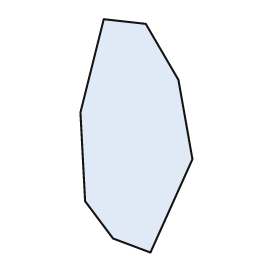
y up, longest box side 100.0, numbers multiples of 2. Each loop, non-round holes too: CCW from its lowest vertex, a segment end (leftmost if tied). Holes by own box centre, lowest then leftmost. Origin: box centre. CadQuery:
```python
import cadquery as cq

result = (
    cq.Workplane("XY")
    .moveTo(6.0, -50.0)
    .lineTo(24.0, -10.0)
    .lineTo(18.0, 24.0)
    .lineTo(4.0, 48.0)
    .lineTo(-14.0, 50.0)
    .lineTo(-24.0, 10.0)
    .lineTo(-22.0, -28.0)
    .lineTo(-10.0, -44.0)
    .close()
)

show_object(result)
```